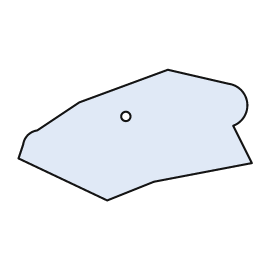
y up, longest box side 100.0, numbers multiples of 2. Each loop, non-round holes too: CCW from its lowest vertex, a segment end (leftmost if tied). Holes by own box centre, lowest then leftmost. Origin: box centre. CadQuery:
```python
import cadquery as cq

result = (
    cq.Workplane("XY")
    .moveTo(-12.0, -28.0)
    .lineTo(8.0, -20.0)
    .lineTo(50.0, -12.0)
    .lineTo(42.0, 4.0)
    .threePointArc((48.0, 14.0), (40.0, 22.0))
    .lineTo(14.0, 28.0)
    .lineTo(-24.0, 14.0)
    .lineTo(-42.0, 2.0)
    .threePointArc((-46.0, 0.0), (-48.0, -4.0))
    .lineTo(-50.0, -10.0)
    .close()
    .moveTo(-4.0, 8.0)
    .circle(2.0)
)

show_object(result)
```